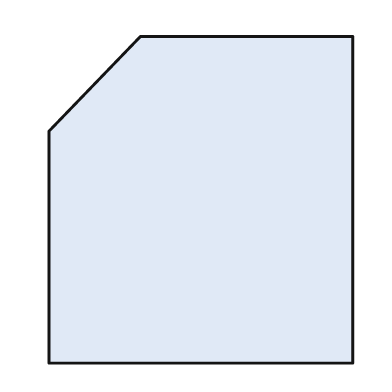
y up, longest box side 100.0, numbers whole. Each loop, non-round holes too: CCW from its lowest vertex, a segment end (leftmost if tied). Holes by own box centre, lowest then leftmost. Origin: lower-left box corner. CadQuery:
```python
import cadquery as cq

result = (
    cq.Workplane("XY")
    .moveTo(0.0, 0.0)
    .lineTo(93.0, 0.0)
    .lineTo(93.0, 100.0)
    .lineTo(28.0, 100.0)
    .lineTo(0.0, 71.0)
    .close()
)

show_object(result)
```